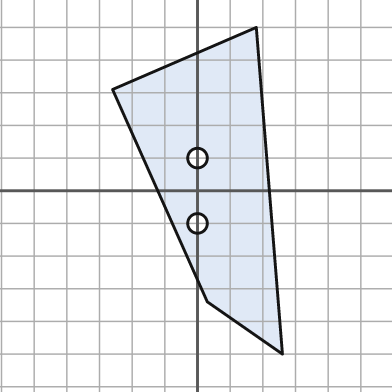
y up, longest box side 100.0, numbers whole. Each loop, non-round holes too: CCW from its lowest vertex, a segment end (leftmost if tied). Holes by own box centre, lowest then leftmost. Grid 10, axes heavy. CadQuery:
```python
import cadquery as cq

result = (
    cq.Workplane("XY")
    .moveTo(26.0, -50.0)
    .lineTo(18.0, 50.0)
    .lineTo(-26.0, 31.0)
    .lineTo(3.0, -34.0)
    .close()
    .moveTo(0.0, -10.0)
    .circle(3.0)
    .moveTo(0.0, 10.0)
    .circle(3.0)
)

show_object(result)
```